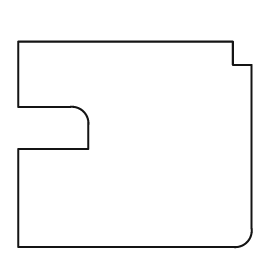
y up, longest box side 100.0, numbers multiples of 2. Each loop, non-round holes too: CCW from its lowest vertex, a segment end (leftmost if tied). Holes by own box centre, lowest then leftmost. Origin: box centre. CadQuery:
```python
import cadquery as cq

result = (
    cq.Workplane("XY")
    .moveTo(-50.0, -44.0)
    .lineTo(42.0, -44.0)
    .threePointArc((48.0, -42.0), (50.0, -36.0))
    .lineTo(50.0, 34.0)
    .lineTo(42.0, 34.0)
    .lineTo(42.0, 44.0)
    .lineTo(-50.0, 44.0)
    .lineTo(-50.0, 16.0)
    .lineTo(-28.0, 16.0)
    .threePointArc((-22.0, 14.0), (-20.0, 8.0))
    .lineTo(-20.0, -2.0)
    .lineTo(-50.0, -2.0)
    .close()
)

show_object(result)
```